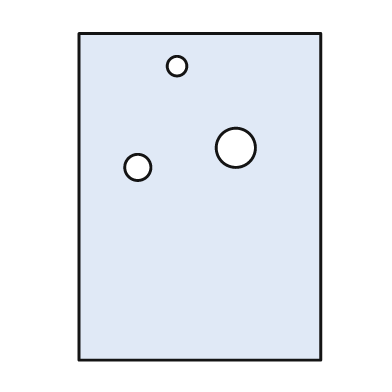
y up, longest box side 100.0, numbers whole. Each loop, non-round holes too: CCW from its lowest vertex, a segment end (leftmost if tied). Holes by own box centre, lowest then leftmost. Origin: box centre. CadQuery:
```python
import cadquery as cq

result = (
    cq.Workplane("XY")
    .moveTo(-37.0, -50.0)
    .lineTo(37.0, -50.0)
    .lineTo(37.0, 50.0)
    .lineTo(-37.0, 50.0)
    .close()
    .moveTo(-19.0, 9.0)
    .circle(4.0)
    .moveTo(11.0, 15.0)
    .circle(6.0)
    .moveTo(-7.0, 40.0)
    .circle(3.0)
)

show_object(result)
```